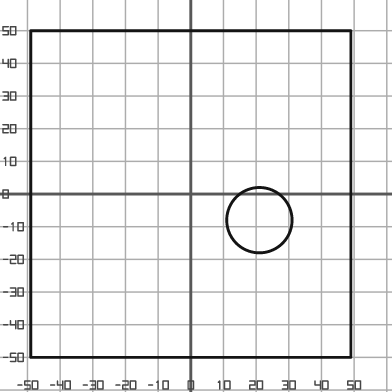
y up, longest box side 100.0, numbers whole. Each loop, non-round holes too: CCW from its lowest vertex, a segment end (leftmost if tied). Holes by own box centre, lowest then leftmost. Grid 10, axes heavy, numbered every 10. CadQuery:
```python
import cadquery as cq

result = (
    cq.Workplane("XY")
    .moveTo(-49.0, -50.0)
    .lineTo(49.0, -50.0)
    .lineTo(49.0, 50.0)
    .lineTo(-49.0, 50.0)
    .close()
    .moveTo(21.0, -8.0)
    .circle(10.0)
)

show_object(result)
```